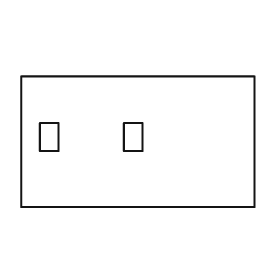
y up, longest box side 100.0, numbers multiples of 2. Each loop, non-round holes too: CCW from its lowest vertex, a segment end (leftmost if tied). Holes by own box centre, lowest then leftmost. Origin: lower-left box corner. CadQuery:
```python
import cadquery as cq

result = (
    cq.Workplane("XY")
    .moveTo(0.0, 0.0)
    .lineTo(100.0, 0.0)
    .lineTo(100.0, 56.0)
    .lineTo(0.0, 56.0)
    .close()
    .moveTo(8.0, 24.0)
    .lineTo(16.0, 24.0)
    .lineTo(16.0, 36.0)
    .lineTo(8.0, 36.0)
    .close()
    .moveTo(44.0, 24.0)
    .lineTo(52.0, 24.0)
    .lineTo(52.0, 36.0)
    .lineTo(44.0, 36.0)
    .close()
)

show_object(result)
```